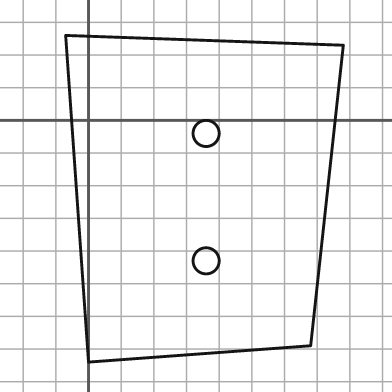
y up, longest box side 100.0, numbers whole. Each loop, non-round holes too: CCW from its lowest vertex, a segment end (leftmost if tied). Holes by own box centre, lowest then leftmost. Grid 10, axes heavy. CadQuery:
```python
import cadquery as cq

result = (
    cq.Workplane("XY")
    .moveTo(0.0, -74.0)
    .lineTo(68.0, -69.0)
    .lineTo(78.0, 23.0)
    .lineTo(-7.0, 26.0)
    .close()
    .moveTo(36.0, -43.0)
    .circle(4.0)
    .moveTo(36.0, -4.0)
    .circle(4.0)
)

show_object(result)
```